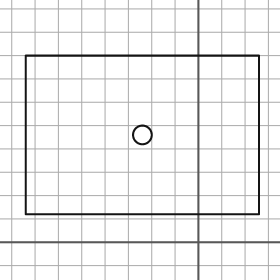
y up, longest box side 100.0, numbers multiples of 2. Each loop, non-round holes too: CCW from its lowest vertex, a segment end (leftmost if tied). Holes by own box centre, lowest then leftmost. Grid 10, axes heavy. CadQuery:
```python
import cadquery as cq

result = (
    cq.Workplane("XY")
    .moveTo(-74.0, 12.0)
    .lineTo(26.0, 12.0)
    .lineTo(26.0, 80.0)
    .lineTo(-74.0, 80.0)
    .close()
    .moveTo(-24.0, 46.0)
    .circle(4.0)
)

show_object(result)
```